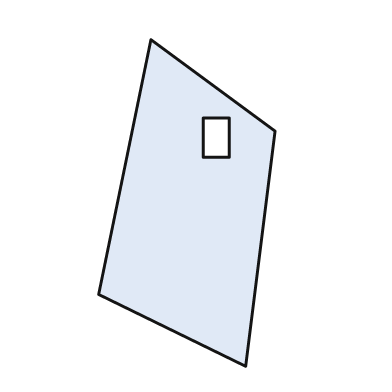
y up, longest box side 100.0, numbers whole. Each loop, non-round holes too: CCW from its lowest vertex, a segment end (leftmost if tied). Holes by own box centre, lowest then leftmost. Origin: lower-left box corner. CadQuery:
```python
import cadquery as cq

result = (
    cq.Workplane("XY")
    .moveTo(45.0, 0.0)
    .lineTo(54.0, 72.0)
    .lineTo(16.0, 100.0)
    .lineTo(0.0, 22.0)
    .close()
    .moveTo(32.0, 64.0)
    .lineTo(40.0, 64.0)
    .lineTo(40.0, 76.0)
    .lineTo(32.0, 76.0)
    .close()
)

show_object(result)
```